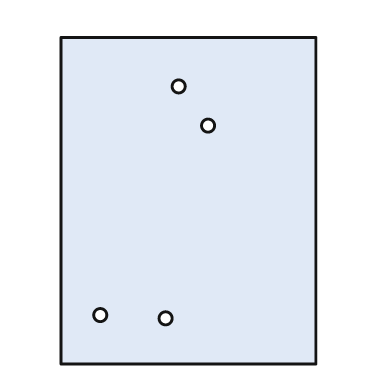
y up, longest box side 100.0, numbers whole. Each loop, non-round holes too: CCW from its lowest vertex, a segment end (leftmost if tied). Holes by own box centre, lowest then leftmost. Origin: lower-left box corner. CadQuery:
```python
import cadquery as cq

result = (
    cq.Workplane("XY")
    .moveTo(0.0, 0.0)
    .lineTo(78.0, 0.0)
    .lineTo(78.0, 100.0)
    .lineTo(0.0, 100.0)
    .close()
    .moveTo(32.0, 14.0)
    .circle(2.0)
    .moveTo(12.0, 15.0)
    .circle(2.0)
    .moveTo(45.0, 73.0)
    .circle(2.0)
    .moveTo(36.0, 85.0)
    .circle(2.0)
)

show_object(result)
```